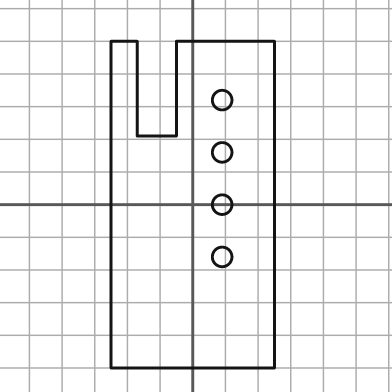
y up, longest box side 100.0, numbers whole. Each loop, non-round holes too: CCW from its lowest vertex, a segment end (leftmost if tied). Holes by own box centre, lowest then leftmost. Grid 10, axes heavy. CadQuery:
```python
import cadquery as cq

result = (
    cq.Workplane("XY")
    .moveTo(-25.0, -50.0)
    .lineTo(25.0, -50.0)
    .lineTo(25.0, 50.0)
    .lineTo(-5.0, 50.0)
    .lineTo(-5.0, 21.0)
    .lineTo(-17.0, 21.0)
    .lineTo(-17.0, 50.0)
    .lineTo(-25.0, 50.0)
    .close()
    .moveTo(9.0, -16.0)
    .circle(3.0)
    .moveTo(9.0, 0.0)
    .circle(3.0)
    .moveTo(9.0, 16.0)
    .circle(3.0)
    .moveTo(9.0, 32.0)
    .circle(3.0)
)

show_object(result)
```